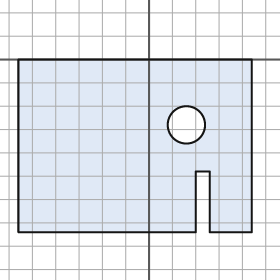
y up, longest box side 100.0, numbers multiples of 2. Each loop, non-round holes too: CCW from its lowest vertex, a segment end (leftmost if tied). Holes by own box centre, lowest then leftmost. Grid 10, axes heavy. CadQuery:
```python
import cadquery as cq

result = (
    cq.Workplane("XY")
    .moveTo(-56.0, -74.0)
    .lineTo(20.0, -74.0)
    .lineTo(20.0, -48.0)
    .lineTo(26.0, -48.0)
    .lineTo(26.0, -74.0)
    .lineTo(44.0, -74.0)
    .lineTo(44.0, 0.0)
    .lineTo(-56.0, 0.0)
    .close()
    .moveTo(16.0, -28.0)
    .circle(8.0)
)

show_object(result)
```